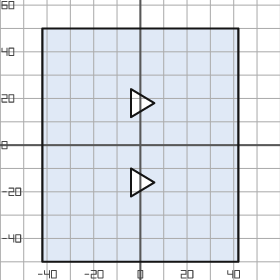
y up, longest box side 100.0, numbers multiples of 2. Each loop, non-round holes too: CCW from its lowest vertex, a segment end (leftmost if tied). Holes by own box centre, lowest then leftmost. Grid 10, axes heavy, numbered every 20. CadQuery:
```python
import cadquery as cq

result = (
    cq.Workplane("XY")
    .moveTo(-42.0, -50.0)
    .lineTo(42.0, -50.0)
    .lineTo(42.0, 50.0)
    .lineTo(-42.0, 50.0)
    .close()
    .moveTo(-4.0, -22.0)
    .lineTo(6.0, -16.0)
    .lineTo(-4.0, -10.0)
    .close()
    .moveTo(-4.0, 12.0)
    .lineTo(6.0, 18.0)
    .lineTo(-4.0, 24.0)
    .close()
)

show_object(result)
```